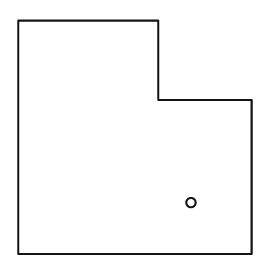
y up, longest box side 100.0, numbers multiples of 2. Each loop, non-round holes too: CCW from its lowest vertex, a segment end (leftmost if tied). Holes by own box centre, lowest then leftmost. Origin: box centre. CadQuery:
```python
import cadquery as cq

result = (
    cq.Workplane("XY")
    .moveTo(-50.0, -50.0)
    .lineTo(50.0, -50.0)
    .lineTo(50.0, 16.0)
    .lineTo(10.0, 16.0)
    .lineTo(10.0, 50.0)
    .lineTo(-50.0, 50.0)
    .close()
    .moveTo(24.0, -28.0)
    .circle(2.0)
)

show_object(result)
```